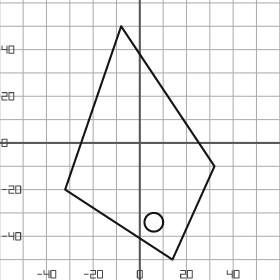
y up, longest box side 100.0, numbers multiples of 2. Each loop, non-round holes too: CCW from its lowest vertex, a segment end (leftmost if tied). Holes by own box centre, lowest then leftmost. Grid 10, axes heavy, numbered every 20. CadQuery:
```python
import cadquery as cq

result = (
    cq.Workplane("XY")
    .moveTo(14.0, -50.0)
    .lineTo(32.0, -10.0)
    .lineTo(-8.0, 50.0)
    .lineTo(-32.0, -20.0)
    .close()
    .moveTo(6.0, -34.0)
    .circle(4.0)
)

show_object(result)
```